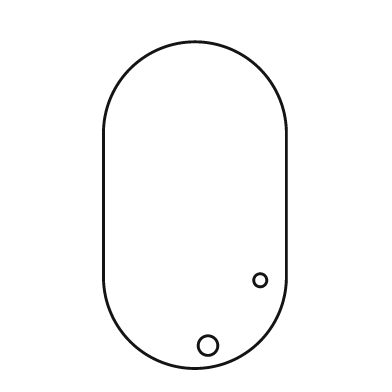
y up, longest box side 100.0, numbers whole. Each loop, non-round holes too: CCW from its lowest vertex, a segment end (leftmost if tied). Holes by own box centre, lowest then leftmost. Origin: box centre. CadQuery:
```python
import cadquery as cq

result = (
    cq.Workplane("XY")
    .moveTo(-28.0, -22.0)
    .threePointArc((0.0, -50.0), (28.0, -22.0))
    .lineTo(28.0, 22.0)
    .threePointArc((0.0, 50.0), (-28.0, 22.0))
    .close()
    .moveTo(4.0, -43.0)
    .circle(3.0)
    .moveTo(20.0, -23.0)
    .circle(2.0)
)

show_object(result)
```